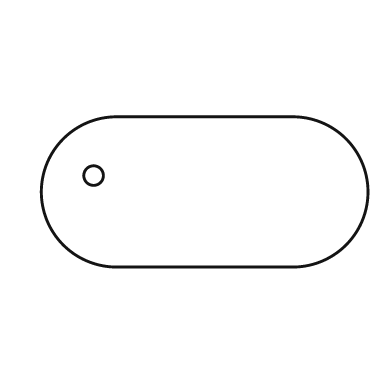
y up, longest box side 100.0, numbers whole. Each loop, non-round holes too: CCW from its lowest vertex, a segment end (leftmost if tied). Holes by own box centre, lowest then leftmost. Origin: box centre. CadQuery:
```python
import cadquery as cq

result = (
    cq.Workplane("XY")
    .moveTo(-27.0, -23.0)
    .lineTo(27.0, -23.0)
    .threePointArc((50.0, 0.0), (27.0, 23.0))
    .lineTo(-27.0, 23.0)
    .threePointArc((-50.0, 0.0), (-27.0, -23.0))
    .close()
    .moveTo(-34.0, 5.0)
    .circle(3.0)
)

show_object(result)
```